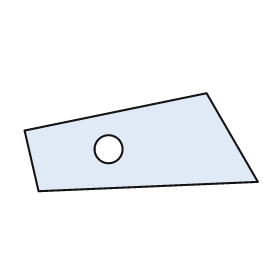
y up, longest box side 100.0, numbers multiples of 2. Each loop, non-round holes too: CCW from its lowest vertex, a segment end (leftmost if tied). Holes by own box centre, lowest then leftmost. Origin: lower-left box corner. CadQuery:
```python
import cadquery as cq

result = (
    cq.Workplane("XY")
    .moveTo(6.0, 0.0)
    .lineTo(100.0, 4.0)
    .lineTo(78.0, 42.0)
    .lineTo(0.0, 26.0)
    .close()
    .moveTo(36.0, 18.0)
    .circle(6.0)
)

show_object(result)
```